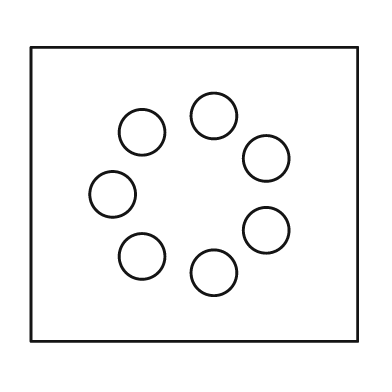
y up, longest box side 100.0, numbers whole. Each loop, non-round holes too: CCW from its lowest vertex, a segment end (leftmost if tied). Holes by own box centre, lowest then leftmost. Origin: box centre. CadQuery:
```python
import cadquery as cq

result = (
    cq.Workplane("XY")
    .moveTo(-50.0, -45.0)
    .lineTo(50.0, -45.0)
    .lineTo(50.0, 45.0)
    .lineTo(-50.0, 45.0)
    .close()
    .moveTo(6.0, -24.0)
    .circle(7.0)
    .moveTo(-16.0, -19.0)
    .circle(7.0)
    .moveTo(22.0, -11.0)
    .circle(7.0)
    .moveTo(-25.0, 0.0)
    .circle(7.0)
    .moveTo(22.0, 11.0)
    .circle(7.0)
    .moveTo(-16.0, 19.0)
    .circle(7.0)
    .moveTo(6.0, 24.0)
    .circle(7.0)
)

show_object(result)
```